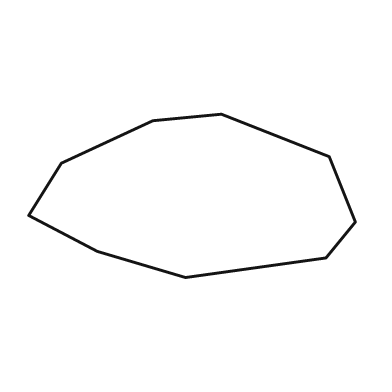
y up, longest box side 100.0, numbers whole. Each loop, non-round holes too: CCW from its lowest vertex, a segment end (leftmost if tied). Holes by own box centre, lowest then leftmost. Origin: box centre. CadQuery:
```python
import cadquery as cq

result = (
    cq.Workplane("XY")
    .moveTo(-2.0, -25.0)
    .lineTo(41.0, -19.0)
    .lineTo(50.0, -8.0)
    .lineTo(42.0, 12.0)
    .lineTo(9.0, 25.0)
    .lineTo(-12.0, 23.0)
    .lineTo(-40.0, 10.0)
    .lineTo(-50.0, -6.0)
    .lineTo(-29.0, -17.0)
    .close()
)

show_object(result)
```